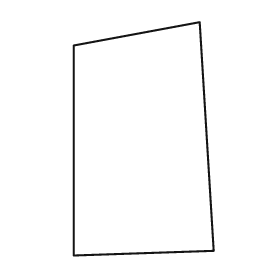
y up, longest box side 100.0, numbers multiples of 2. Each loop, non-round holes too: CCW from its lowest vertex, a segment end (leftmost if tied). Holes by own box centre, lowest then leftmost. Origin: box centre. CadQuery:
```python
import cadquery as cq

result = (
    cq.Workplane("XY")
    .moveTo(-30.0, -50.0)
    .lineTo(30.0, -48.0)
    .lineTo(24.0, 50.0)
    .lineTo(-30.0, 40.0)
    .close()
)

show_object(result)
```